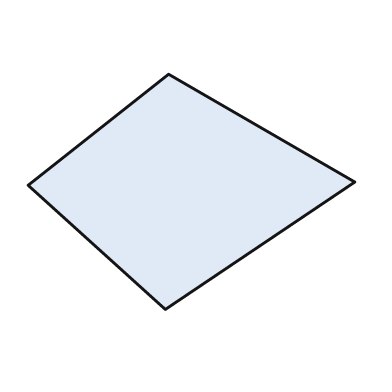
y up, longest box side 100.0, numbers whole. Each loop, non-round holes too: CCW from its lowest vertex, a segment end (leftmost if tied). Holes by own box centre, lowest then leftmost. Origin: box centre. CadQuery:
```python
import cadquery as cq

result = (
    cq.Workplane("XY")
    .moveTo(-8.0, -36.0)
    .lineTo(50.0, 3.0)
    .lineTo(-7.0, 36.0)
    .lineTo(-50.0, 2.0)
    .close()
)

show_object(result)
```